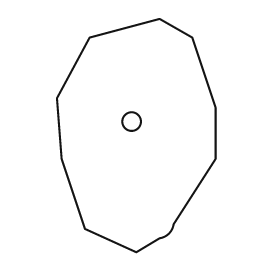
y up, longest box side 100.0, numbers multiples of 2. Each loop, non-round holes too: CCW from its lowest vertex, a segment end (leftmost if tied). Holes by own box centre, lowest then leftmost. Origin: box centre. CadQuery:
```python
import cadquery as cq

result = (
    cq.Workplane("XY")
    .moveTo(0.0, -50.0)
    .lineTo(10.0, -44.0)
    .threePointArc((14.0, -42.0), (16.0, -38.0))
    .lineTo(34.0, -10.0)
    .lineTo(34.0, 12.0)
    .lineTo(24.0, 42.0)
    .lineTo(10.0, 50.0)
    .lineTo(-20.0, 42.0)
    .lineTo(-34.0, 16.0)
    .lineTo(-32.0, -10.0)
    .lineTo(-22.0, -40.0)
    .close()
    .moveTo(-2.0, 6.0)
    .circle(4.0)
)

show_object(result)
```